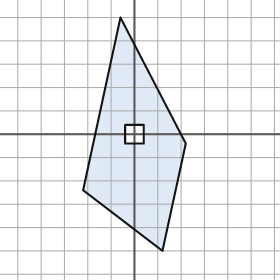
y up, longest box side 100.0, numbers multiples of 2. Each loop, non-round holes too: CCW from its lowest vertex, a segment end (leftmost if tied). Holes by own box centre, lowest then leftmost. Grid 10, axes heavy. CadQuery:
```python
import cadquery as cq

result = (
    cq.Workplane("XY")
    .moveTo(12.0, -50.0)
    .lineTo(22.0, -4.0)
    .lineTo(-6.0, 50.0)
    .lineTo(-22.0, -24.0)
    .close()
    .moveTo(-4.0, -4.0)
    .lineTo(4.0, -4.0)
    .lineTo(4.0, 4.0)
    .lineTo(-4.0, 4.0)
    .close()
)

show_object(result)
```